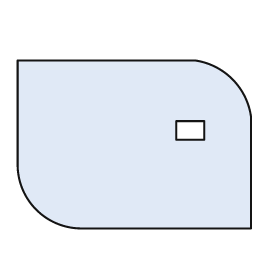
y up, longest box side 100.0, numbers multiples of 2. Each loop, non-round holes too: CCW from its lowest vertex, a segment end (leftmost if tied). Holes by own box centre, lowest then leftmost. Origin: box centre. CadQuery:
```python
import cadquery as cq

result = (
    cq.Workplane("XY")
    .moveTo(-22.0, -36.0)
    .lineTo(50.0, -36.0)
    .lineTo(50.0, 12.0)
    .threePointArc((42.0, 28.0), (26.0, 36.0))
    .lineTo(-50.0, 36.0)
    .lineTo(-50.0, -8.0)
    .threePointArc((-42.0, -28.0), (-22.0, -36.0))
    .close()
    .moveTo(18.0, 2.0)
    .lineTo(30.0, 2.0)
    .lineTo(30.0, 10.0)
    .lineTo(18.0, 10.0)
    .close()
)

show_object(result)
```